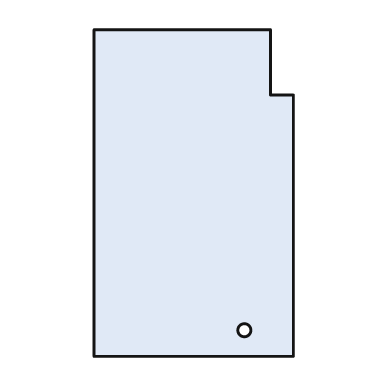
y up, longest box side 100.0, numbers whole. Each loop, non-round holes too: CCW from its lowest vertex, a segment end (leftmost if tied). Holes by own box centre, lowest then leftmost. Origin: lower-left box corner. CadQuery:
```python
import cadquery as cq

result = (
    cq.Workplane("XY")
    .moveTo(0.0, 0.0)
    .lineTo(61.0, 0.0)
    .lineTo(61.0, 80.0)
    .lineTo(54.0, 80.0)
    .lineTo(54.0, 100.0)
    .lineTo(0.0, 100.0)
    .close()
    .moveTo(46.0, 8.0)
    .circle(2.0)
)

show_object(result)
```